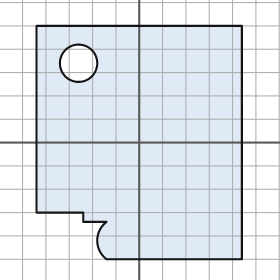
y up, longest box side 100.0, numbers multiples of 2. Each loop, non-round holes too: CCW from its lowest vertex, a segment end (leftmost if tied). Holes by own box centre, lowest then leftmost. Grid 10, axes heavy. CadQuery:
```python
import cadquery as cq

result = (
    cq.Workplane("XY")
    .moveTo(-14.0, -50.0)
    .lineTo(44.0, -50.0)
    .lineTo(44.0, 50.0)
    .lineTo(-44.0, 50.0)
    .lineTo(-44.0, -30.0)
    .lineTo(-24.0, -30.0)
    .lineTo(-24.0, -34.0)
    .lineTo(-14.0, -34.0)
    .threePointArc((-18.0, -42.0), (-14.0, -50.0))
    .close()
    .moveTo(-26.0, 34.0)
    .circle(8.0)
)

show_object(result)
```